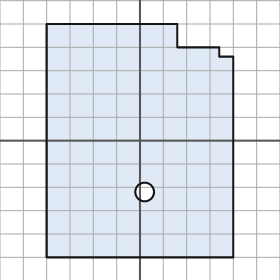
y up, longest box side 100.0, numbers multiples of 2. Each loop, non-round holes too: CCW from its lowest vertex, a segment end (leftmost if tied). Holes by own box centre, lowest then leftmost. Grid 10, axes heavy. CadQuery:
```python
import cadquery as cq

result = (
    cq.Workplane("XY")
    .moveTo(-40.0, -50.0)
    .lineTo(40.0, -50.0)
    .lineTo(40.0, 36.0)
    .lineTo(34.0, 36.0)
    .lineTo(34.0, 40.0)
    .lineTo(16.0, 40.0)
    .lineTo(16.0, 50.0)
    .lineTo(-40.0, 50.0)
    .close()
    .moveTo(2.0, -22.0)
    .circle(4.0)
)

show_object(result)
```